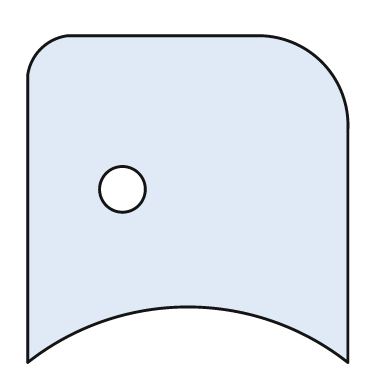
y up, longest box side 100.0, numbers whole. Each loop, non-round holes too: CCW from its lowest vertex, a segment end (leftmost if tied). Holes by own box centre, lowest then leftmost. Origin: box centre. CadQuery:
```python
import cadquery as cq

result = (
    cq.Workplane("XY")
    .moveTo(-49.0, -50.0)
    .threePointArc((0.0, -33.0), (49.0, -50.0))
    .lineTo(49.0, 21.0)
    .threePointArc((41.0, 42.0), (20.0, 50.0))
    .lineTo(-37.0, 50.0)
    .threePointArc((-45.0, 46.0), (-49.0, 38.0))
    .close()
    .moveTo(-20.0, 3.0)
    .circle(7.0)
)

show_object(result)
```